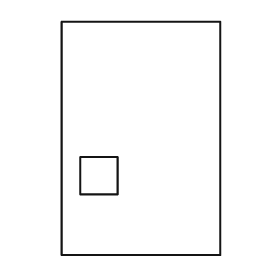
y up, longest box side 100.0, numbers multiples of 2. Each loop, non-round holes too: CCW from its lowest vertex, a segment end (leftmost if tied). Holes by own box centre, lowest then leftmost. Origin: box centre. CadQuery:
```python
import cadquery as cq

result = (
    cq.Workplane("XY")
    .moveTo(-34.0, -50.0)
    .lineTo(34.0, -50.0)
    .lineTo(34.0, 50.0)
    .lineTo(-34.0, 50.0)
    .close()
    .moveTo(-26.0, -24.0)
    .lineTo(-10.0, -24.0)
    .lineTo(-10.0, -8.0)
    .lineTo(-26.0, -8.0)
    .close()
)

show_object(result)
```